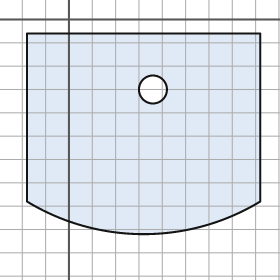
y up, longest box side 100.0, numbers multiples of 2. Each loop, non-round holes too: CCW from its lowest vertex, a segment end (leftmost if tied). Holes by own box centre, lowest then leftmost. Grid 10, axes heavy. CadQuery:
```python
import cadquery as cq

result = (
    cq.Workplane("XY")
    .moveTo(-18.0, -78.0)
    .threePointArc((32.0, -92.0), (82.0, -78.0))
    .lineTo(82.0, -6.0)
    .lineTo(-18.0, -6.0)
    .close()
    .moveTo(36.0, -30.0)
    .circle(6.0)
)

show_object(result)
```